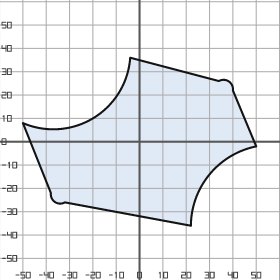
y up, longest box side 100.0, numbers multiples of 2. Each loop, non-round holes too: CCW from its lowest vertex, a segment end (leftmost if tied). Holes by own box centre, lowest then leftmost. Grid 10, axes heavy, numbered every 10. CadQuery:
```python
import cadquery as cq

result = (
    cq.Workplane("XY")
    .moveTo(22.0, -36.0)
    .threePointArc((30.0, -14.0), (50.0, -2.0))
    .lineTo(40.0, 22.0)
    .threePointArc((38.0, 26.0), (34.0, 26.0))
    .lineTo(-4.0, 36.0)
    .threePointArc((-20.0, 10.0), (-50.0, 8.0))
    .lineTo(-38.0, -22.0)
    .threePointArc((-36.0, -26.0), (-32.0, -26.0))
    .close()
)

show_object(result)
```